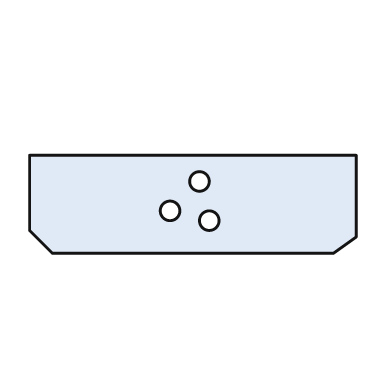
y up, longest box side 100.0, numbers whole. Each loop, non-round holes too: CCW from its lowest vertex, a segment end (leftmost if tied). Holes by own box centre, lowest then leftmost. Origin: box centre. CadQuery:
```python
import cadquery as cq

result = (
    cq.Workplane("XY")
    .moveTo(-43.0, -15.0)
    .lineTo(43.0, -15.0)
    .lineTo(50.0, -10.0)
    .lineTo(50.0, 15.0)
    .lineTo(-50.0, 15.0)
    .lineTo(-50.0, -8.0)
    .close()
    .moveTo(5.0, -5.0)
    .circle(3.0)
    .moveTo(-7.0, -2.0)
    .circle(3.0)
    .moveTo(2.0, 7.0)
    .circle(3.0)
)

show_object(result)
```